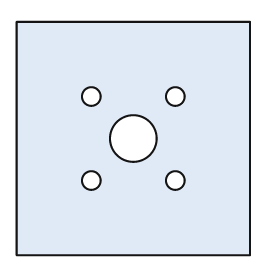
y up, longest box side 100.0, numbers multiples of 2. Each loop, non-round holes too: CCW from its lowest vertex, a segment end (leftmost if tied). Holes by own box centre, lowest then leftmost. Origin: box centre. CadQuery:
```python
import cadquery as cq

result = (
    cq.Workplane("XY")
    .moveTo(-50.0, -50.0)
    .lineTo(50.0, -50.0)
    .lineTo(50.0, 50.0)
    .lineTo(-50.0, 50.0)
    .close()
    .moveTo(-18.0, -18.0)
    .circle(4.0)
    .moveTo(18.0, -18.0)
    .circle(4.0)
    .moveTo(0.0, 0.0)
    .circle(10.0)
    .moveTo(-18.0, 18.0)
    .circle(4.0)
    .moveTo(18.0, 18.0)
    .circle(4.0)
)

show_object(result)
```